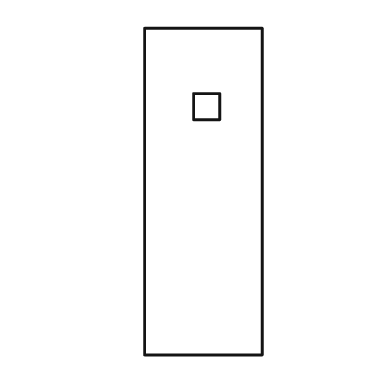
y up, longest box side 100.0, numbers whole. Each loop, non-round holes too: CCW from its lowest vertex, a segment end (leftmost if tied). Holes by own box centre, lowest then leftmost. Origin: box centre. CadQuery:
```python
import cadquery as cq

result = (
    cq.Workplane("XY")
    .moveTo(-18.0, -50.0)
    .lineTo(18.0, -50.0)
    .lineTo(18.0, 50.0)
    .lineTo(-18.0, 50.0)
    .close()
    .moveTo(-3.0, 22.0)
    .lineTo(5.0, 22.0)
    .lineTo(5.0, 30.0)
    .lineTo(-3.0, 30.0)
    .close()
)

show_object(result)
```